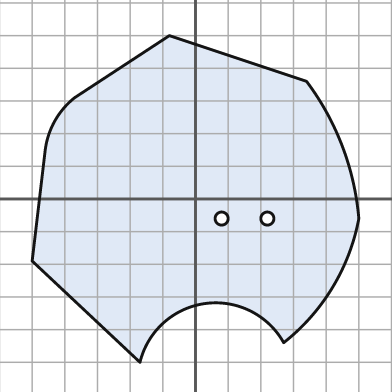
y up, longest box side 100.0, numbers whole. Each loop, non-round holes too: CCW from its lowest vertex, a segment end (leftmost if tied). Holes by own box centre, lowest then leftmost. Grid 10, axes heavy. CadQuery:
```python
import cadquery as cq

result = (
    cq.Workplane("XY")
    .moveTo(-17.0, -50.0)
    .threePointArc((3.0, -32.0), (27.0, -44.0))
    .threePointArc((42.0, -27.0), (50.0, -6.0))
    .threePointArc((45.0, 16.0), (34.0, 36.0))
    .lineTo(-8.0, 50.0)
    .lineTo(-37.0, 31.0)
    .threePointArc((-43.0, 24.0), (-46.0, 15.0))
    .lineTo(-50.0, -19.0)
    .close()
    .moveTo(8.0, -6.0)
    .circle(2.0)
    .moveTo(22.0, -6.0)
    .circle(2.0)
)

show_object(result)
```